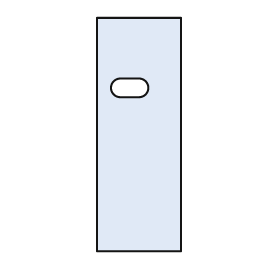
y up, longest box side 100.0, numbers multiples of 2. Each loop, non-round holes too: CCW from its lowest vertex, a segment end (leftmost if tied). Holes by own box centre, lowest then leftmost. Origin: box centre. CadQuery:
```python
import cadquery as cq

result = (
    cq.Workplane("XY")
    .moveTo(-18.0, -50.0)
    .lineTo(18.0, -50.0)
    .lineTo(18.0, 50.0)
    .lineTo(-18.0, 50.0)
    .close()
    .moveTo(-8.0, 16.0)
    .lineTo(0.0, 16.0)
    .threePointArc((4.0, 20.0), (0.0, 24.0))
    .lineTo(-8.0, 24.0)
    .threePointArc((-12.0, 20.0), (-8.0, 16.0))
    .close()
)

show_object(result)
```